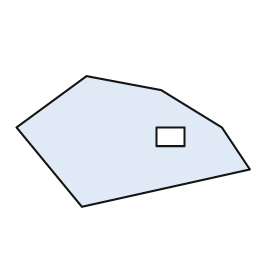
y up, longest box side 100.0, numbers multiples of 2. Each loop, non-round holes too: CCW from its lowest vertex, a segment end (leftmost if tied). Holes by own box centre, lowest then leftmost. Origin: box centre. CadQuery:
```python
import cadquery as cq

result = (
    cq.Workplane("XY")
    .moveTo(-22.0, -28.0)
    .lineTo(50.0, -12.0)
    .lineTo(38.0, 6.0)
    .lineTo(12.0, 22.0)
    .lineTo(-20.0, 28.0)
    .lineTo(-50.0, 6.0)
    .close()
    .moveTo(10.0, -2.0)
    .lineTo(22.0, -2.0)
    .lineTo(22.0, 6.0)
    .lineTo(10.0, 6.0)
    .close()
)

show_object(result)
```